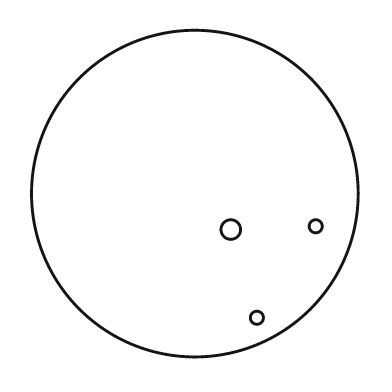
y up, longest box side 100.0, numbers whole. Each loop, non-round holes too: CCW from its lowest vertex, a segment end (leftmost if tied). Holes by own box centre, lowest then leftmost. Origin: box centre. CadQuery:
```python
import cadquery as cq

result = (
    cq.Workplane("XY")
    .moveTo(0.0, 0.0)
    .circle(50.0)
    .moveTo(19.0, -38.0)
    .circle(2.0)
    .moveTo(11.0, -11.0)
    .circle(3.0)
    .moveTo(37.0, -10.0)
    .circle(2.0)
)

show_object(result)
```